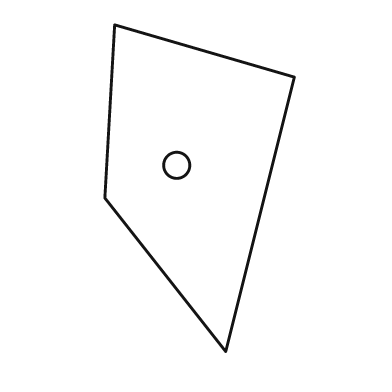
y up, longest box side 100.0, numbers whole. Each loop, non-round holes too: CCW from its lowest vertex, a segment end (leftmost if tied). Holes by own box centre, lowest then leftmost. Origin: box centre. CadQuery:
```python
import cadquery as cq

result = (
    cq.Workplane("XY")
    .moveTo(8.0, -50.0)
    .lineTo(29.0, 34.0)
    .lineTo(-26.0, 50.0)
    .lineTo(-29.0, -3.0)
    .close()
    .moveTo(-7.0, 7.0)
    .circle(4.0)
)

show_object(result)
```